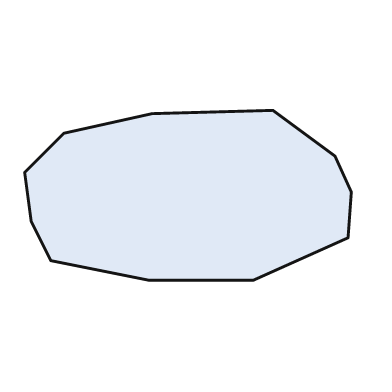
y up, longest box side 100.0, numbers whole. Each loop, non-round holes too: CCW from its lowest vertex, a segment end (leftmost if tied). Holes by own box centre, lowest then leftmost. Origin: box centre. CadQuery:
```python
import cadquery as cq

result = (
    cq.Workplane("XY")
    .moveTo(-12.0, -26.0)
    .lineTo(20.0, -26.0)
    .lineTo(49.0, -13.0)
    .lineTo(50.0, 1.0)
    .lineTo(45.0, 12.0)
    .lineTo(26.0, 26.0)
    .lineTo(-11.0, 25.0)
    .lineTo(-38.0, 19.0)
    .lineTo(-50.0, 7.0)
    .lineTo(-48.0, -8.0)
    .lineTo(-42.0, -20.0)
    .close()
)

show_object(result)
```